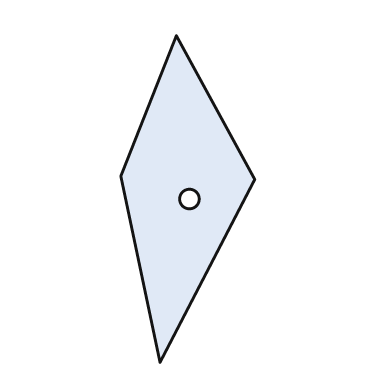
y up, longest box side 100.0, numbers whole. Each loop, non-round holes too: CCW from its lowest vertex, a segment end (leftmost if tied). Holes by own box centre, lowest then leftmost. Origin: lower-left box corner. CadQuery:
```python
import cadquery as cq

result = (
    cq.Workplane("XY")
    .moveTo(12.0, 0.0)
    .lineTo(41.0, 56.0)
    .lineTo(17.0, 100.0)
    .lineTo(0.0, 57.0)
    .close()
    .moveTo(21.0, 50.0)
    .circle(3.0)
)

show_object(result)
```